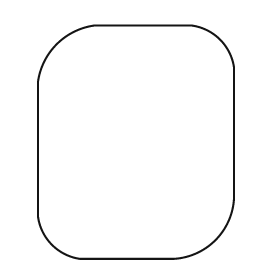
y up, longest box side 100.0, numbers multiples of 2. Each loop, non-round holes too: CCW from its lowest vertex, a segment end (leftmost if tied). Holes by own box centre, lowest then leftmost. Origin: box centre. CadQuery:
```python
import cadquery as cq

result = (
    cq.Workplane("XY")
    .moveTo(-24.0, -50.0)
    .lineTo(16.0, -50.0)
    .threePointArc((34.0, -42.0), (42.0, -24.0))
    .lineTo(42.0, 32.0)
    .threePointArc((36.0, 44.0), (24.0, 50.0))
    .lineTo(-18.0, 50.0)
    .threePointArc((-34.0, 42.0), (-42.0, 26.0))
    .lineTo(-42.0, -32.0)
    .threePointArc((-36.0, -44.0), (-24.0, -50.0))
    .close()
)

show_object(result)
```